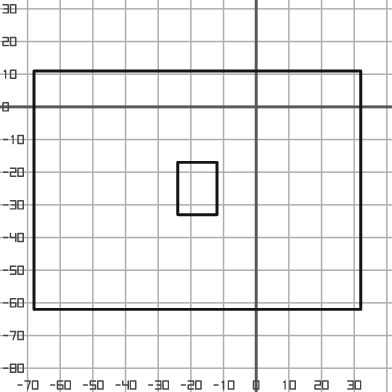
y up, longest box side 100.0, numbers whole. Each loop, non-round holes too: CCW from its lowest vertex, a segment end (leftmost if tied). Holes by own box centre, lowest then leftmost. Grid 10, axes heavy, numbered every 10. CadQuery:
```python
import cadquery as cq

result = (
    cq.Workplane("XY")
    .moveTo(-68.0, -62.0)
    .lineTo(32.0, -62.0)
    .lineTo(32.0, 11.0)
    .lineTo(-68.0, 11.0)
    .close()
    .moveTo(-24.0, -33.0)
    .lineTo(-12.0, -33.0)
    .lineTo(-12.0, -17.0)
    .lineTo(-24.0, -17.0)
    .close()
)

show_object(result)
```